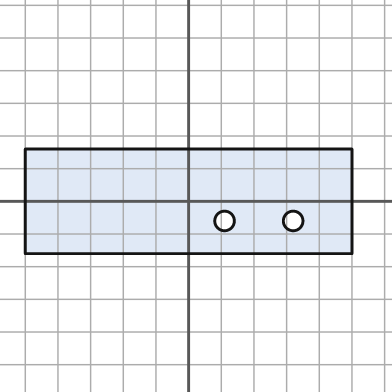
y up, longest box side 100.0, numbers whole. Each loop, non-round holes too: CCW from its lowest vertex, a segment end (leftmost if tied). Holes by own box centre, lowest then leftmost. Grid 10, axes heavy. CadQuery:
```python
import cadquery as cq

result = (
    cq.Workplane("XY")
    .moveTo(-50.0, -16.0)
    .lineTo(50.0, -16.0)
    .lineTo(50.0, 16.0)
    .lineTo(-50.0, 16.0)
    .close()
    .moveTo(11.0, -6.0)
    .circle(3.0)
    .moveTo(32.0, -6.0)
    .circle(3.0)
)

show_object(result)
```